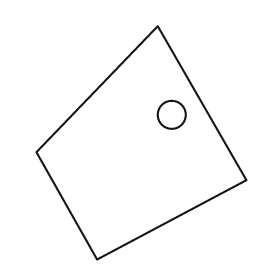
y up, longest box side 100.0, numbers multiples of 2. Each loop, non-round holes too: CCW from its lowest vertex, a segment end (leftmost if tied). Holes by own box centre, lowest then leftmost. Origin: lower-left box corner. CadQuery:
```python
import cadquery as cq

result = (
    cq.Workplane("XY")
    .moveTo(26.0, 0.0)
    .lineTo(90.0, 34.0)
    .lineTo(52.0, 100.0)
    .lineTo(0.0, 46.0)
    .close()
    .moveTo(58.0, 62.0)
    .circle(6.0)
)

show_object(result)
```